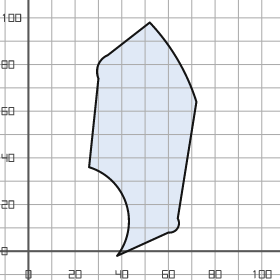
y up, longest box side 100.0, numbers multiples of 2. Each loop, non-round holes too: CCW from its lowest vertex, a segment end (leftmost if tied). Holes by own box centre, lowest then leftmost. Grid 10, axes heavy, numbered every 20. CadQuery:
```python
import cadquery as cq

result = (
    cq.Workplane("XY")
    .moveTo(38.0, -2.0)
    .lineTo(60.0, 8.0)
    .threePointArc((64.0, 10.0), (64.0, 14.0))
    .lineTo(72.0, 64.0)
    .threePointArc((64.0, 82.0), (52.0, 98.0))
    .lineTo(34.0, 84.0)
    .threePointArc((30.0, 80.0), (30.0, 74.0))
    .lineTo(26.0, 36.0)
    .threePointArc((42.0, 20.0), (38.0, -2.0))
    .close()
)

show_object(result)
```